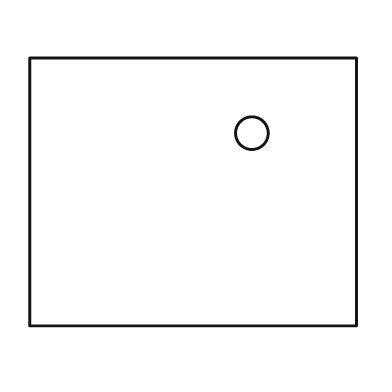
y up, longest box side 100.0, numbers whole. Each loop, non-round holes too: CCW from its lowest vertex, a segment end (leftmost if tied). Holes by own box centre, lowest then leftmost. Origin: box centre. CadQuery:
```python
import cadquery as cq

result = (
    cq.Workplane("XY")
    .moveTo(-50.0, -41.0)
    .lineTo(50.0, -41.0)
    .lineTo(50.0, 41.0)
    .lineTo(-50.0, 41.0)
    .close()
    .moveTo(18.0, 18.0)
    .circle(5.0)
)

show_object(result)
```